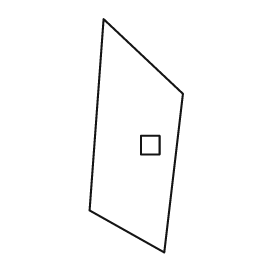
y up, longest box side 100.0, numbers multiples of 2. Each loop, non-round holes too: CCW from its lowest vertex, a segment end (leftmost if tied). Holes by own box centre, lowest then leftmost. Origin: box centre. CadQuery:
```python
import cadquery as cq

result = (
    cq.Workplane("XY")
    .moveTo(12.0, -50.0)
    .lineTo(20.0, 18.0)
    .lineTo(-14.0, 50.0)
    .lineTo(-20.0, -32.0)
    .close()
    .moveTo(2.0, -8.0)
    .lineTo(10.0, -8.0)
    .lineTo(10.0, 0.0)
    .lineTo(2.0, 0.0)
    .close()
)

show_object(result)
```